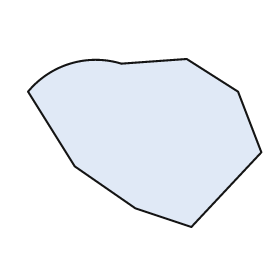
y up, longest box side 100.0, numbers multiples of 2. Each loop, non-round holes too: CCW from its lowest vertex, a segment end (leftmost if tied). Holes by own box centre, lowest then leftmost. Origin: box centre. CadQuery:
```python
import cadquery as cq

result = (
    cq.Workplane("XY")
    .moveTo(20.0, -36.0)
    .lineTo(50.0, -4.0)
    .lineTo(40.0, 22.0)
    .lineTo(18.0, 36.0)
    .lineTo(-10.0, 34.0)
    .threePointArc((-32.0, 34.0), (-50.0, 22.0))
    .lineTo(-30.0, -10.0)
    .lineTo(-4.0, -28.0)
    .close()
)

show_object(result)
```